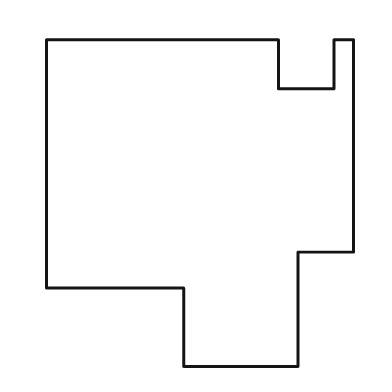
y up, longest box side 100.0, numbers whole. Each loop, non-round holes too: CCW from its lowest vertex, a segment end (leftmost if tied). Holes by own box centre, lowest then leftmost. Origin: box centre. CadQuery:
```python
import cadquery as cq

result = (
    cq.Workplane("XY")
    .moveTo(-5.0, -50.0)
    .lineTo(30.0, -50.0)
    .lineTo(30.0, -15.0)
    .lineTo(47.0, -15.0)
    .lineTo(47.0, 50.0)
    .lineTo(41.0, 50.0)
    .lineTo(41.0, 35.0)
    .lineTo(24.0, 35.0)
    .lineTo(24.0, 50.0)
    .lineTo(-47.0, 50.0)
    .lineTo(-47.0, -26.0)
    .lineTo(-5.0, -26.0)
    .close()
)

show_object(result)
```